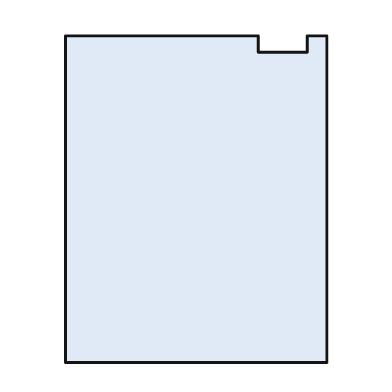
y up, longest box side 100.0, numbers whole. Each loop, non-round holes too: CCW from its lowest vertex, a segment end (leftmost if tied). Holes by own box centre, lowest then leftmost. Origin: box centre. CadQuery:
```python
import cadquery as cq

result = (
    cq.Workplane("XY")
    .moveTo(-40.0, -50.0)
    .lineTo(40.0, -50.0)
    .lineTo(40.0, 50.0)
    .lineTo(34.0, 50.0)
    .lineTo(34.0, 45.0)
    .lineTo(19.0, 45.0)
    .lineTo(19.0, 50.0)
    .lineTo(-40.0, 50.0)
    .close()
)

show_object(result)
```